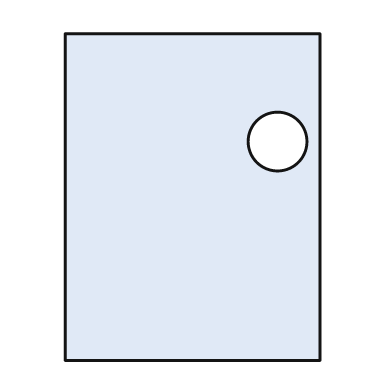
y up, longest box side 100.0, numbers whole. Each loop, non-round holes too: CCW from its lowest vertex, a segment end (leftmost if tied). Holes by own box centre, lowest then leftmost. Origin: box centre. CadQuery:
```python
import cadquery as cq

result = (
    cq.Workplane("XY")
    .moveTo(-39.0, -50.0)
    .lineTo(39.0, -50.0)
    .lineTo(39.0, 50.0)
    .lineTo(-39.0, 50.0)
    .close()
    .moveTo(26.0, 17.0)
    .circle(9.0)
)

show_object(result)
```